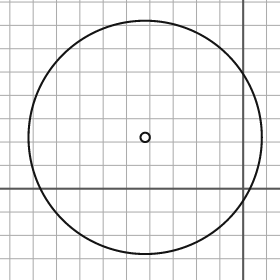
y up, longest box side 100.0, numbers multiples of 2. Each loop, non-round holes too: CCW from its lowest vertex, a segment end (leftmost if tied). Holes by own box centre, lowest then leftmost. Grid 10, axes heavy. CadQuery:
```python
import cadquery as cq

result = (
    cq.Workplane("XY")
    .moveTo(-42.0, 22.0)
    .circle(50.0)
    .moveTo(-42.0, 22.0)
    .circle(2.0)
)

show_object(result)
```